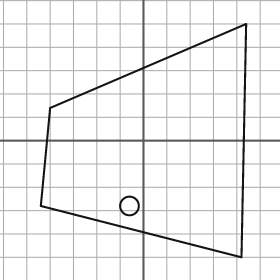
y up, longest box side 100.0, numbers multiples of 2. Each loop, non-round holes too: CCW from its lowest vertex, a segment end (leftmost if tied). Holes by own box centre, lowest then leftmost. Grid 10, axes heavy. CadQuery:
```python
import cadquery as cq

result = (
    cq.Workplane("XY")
    .moveTo(42.0, -50.0)
    .lineTo(44.0, 50.0)
    .lineTo(-40.0, 14.0)
    .lineTo(-44.0, -28.0)
    .close()
    .moveTo(-6.0, -28.0)
    .circle(4.0)
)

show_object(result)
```